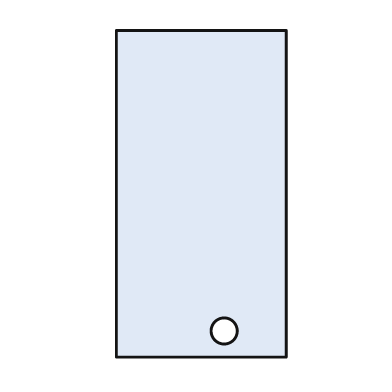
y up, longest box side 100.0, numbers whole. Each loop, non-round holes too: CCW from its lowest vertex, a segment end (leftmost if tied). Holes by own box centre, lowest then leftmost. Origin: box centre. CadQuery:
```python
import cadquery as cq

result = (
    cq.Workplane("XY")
    .moveTo(-26.0, -50.0)
    .lineTo(26.0, -50.0)
    .lineTo(26.0, 50.0)
    .lineTo(-26.0, 50.0)
    .close()
    .moveTo(7.0, -42.0)
    .circle(4.0)
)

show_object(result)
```